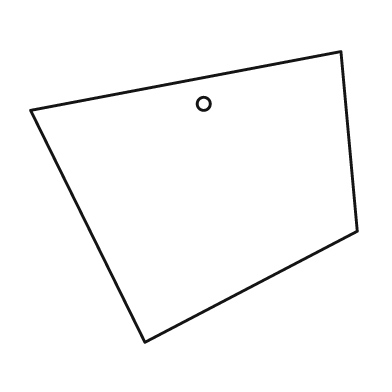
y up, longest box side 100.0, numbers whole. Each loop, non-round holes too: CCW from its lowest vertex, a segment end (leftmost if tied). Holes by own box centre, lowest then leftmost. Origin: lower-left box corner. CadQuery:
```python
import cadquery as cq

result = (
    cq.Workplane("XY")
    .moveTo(35.0, 0.0)
    .lineTo(100.0, 34.0)
    .lineTo(95.0, 89.0)
    .lineTo(0.0, 71.0)
    .close()
    .moveTo(53.0, 73.0)
    .circle(2.0)
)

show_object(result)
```